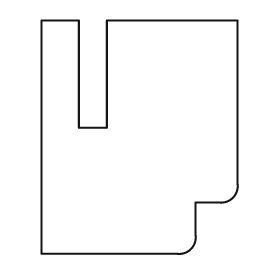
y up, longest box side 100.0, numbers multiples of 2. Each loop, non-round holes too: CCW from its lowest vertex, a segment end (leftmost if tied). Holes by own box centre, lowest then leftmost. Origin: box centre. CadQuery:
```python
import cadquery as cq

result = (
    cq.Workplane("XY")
    .moveTo(-42.0, -50.0)
    .lineTo(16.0, -50.0)
    .threePointArc((22.0, -48.0), (24.0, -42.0))
    .lineTo(24.0, -28.0)
    .lineTo(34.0, -28.0)
    .threePointArc((40.0, -26.0), (42.0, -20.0))
    .lineTo(42.0, 50.0)
    .lineTo(-14.0, 50.0)
    .lineTo(-14.0, 4.0)
    .lineTo(-26.0, 4.0)
    .lineTo(-26.0, 50.0)
    .lineTo(-42.0, 50.0)
    .close()
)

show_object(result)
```